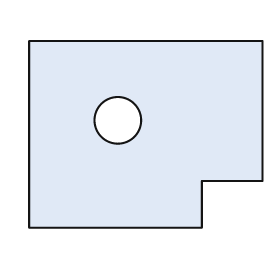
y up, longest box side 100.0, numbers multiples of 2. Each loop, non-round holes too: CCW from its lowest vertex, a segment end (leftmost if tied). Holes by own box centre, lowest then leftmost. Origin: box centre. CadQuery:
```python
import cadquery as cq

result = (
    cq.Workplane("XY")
    .moveTo(-50.0, -40.0)
    .lineTo(24.0, -40.0)
    .lineTo(24.0, -20.0)
    .lineTo(50.0, -20.0)
    .lineTo(50.0, 40.0)
    .lineTo(-50.0, 40.0)
    .close()
    .moveTo(-12.0, 6.0)
    .circle(10.0)
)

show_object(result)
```